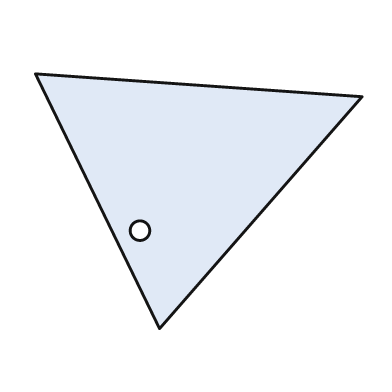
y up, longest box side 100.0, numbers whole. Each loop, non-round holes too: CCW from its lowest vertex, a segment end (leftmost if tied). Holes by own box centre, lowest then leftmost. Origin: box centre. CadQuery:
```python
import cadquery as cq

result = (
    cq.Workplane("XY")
    .moveTo(-12.0, -39.0)
    .lineTo(50.0, 32.0)
    .lineTo(-50.0, 39.0)
    .close()
    .moveTo(-18.0, -9.0)
    .circle(3.0)
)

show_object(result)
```